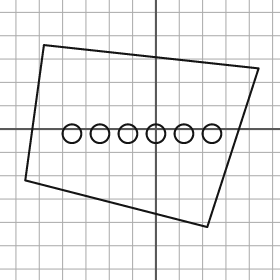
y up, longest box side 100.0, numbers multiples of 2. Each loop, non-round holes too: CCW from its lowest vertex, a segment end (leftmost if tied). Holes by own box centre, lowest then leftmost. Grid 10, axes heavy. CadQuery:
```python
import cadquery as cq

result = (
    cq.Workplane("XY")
    .moveTo(22.0, -42.0)
    .lineTo(44.0, 26.0)
    .lineTo(-48.0, 36.0)
    .lineTo(-56.0, -22.0)
    .close()
    .moveTo(-36.0, -2.0)
    .circle(4.0)
    .moveTo(-24.0, -2.0)
    .circle(4.0)
    .moveTo(-12.0, -2.0)
    .circle(4.0)
    .moveTo(0.0, -2.0)
    .circle(4.0)
    .moveTo(12.0, -2.0)
    .circle(4.0)
    .moveTo(24.0, -2.0)
    .circle(4.0)
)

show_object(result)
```